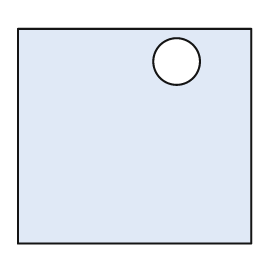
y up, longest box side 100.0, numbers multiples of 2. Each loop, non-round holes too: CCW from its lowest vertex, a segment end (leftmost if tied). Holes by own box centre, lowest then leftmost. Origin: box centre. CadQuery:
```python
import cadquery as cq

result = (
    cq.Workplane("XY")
    .moveTo(-50.0, -46.0)
    .lineTo(50.0, -46.0)
    .lineTo(50.0, 46.0)
    .lineTo(-50.0, 46.0)
    .close()
    .moveTo(18.0, 32.0)
    .circle(10.0)
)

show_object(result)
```